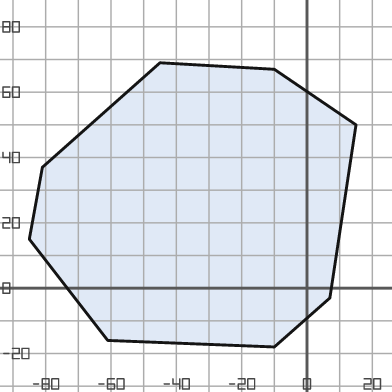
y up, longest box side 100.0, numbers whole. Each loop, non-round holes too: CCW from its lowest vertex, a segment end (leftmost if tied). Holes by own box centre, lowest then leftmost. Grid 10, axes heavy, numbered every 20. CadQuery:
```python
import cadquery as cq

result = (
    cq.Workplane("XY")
    .moveTo(-10.0, -18.0)
    .lineTo(7.0, -3.0)
    .lineTo(15.0, 50.0)
    .lineTo(-10.0, 67.0)
    .lineTo(-45.0, 69.0)
    .lineTo(-81.0, 37.0)
    .lineTo(-85.0, 15.0)
    .lineTo(-61.0, -16.0)
    .close()
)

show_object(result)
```